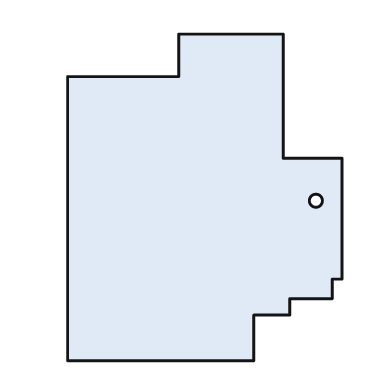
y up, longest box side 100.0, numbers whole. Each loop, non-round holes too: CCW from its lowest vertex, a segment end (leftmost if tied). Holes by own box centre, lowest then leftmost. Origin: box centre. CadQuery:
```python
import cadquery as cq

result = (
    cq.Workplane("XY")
    .moveTo(-42.0, -50.0)
    .lineTo(15.0, -50.0)
    .lineTo(15.0, -36.0)
    .lineTo(26.0, -36.0)
    .lineTo(26.0, -31.0)
    .lineTo(39.0, -31.0)
    .lineTo(39.0, -25.0)
    .lineTo(42.0, -25.0)
    .lineTo(42.0, 12.0)
    .lineTo(24.0, 12.0)
    .lineTo(24.0, 50.0)
    .lineTo(-8.0, 50.0)
    .lineTo(-8.0, 37.0)
    .lineTo(-42.0, 37.0)
    .close()
    .moveTo(34.0, -1.0)
    .circle(2.0)
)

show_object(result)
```